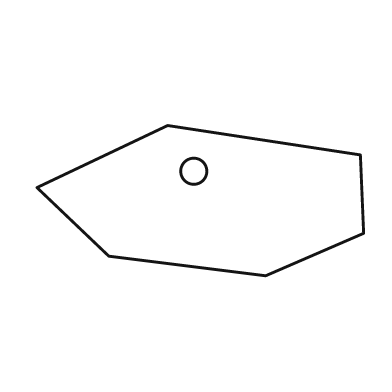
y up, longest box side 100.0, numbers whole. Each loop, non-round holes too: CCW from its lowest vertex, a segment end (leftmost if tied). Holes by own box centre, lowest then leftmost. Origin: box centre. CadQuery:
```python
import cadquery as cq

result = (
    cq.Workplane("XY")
    .moveTo(20.0, -23.0)
    .lineTo(50.0, -10.0)
    .lineTo(49.0, 14.0)
    .lineTo(-10.0, 23.0)
    .lineTo(-50.0, 4.0)
    .lineTo(-28.0, -17.0)
    .close()
    .moveTo(-2.0, 9.0)
    .circle(4.0)
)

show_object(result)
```